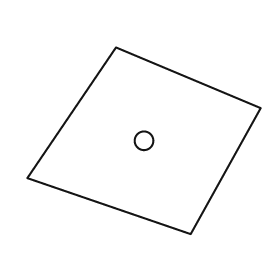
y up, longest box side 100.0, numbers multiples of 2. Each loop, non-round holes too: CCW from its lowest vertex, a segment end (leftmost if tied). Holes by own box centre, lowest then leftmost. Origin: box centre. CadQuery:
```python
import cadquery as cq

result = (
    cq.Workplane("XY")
    .moveTo(20.0, -40.0)
    .lineTo(50.0, 14.0)
    .lineTo(-12.0, 40.0)
    .lineTo(-50.0, -16.0)
    .close()
    .moveTo(0.0, 0.0)
    .circle(4.0)
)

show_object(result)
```